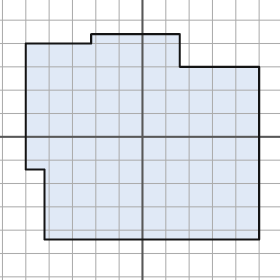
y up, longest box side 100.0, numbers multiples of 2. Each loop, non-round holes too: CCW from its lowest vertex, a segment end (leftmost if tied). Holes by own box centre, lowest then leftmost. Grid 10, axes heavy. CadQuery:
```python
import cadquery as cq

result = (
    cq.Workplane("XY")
    .moveTo(-42.0, -44.0)
    .lineTo(50.0, -44.0)
    .lineTo(50.0, 30.0)
    .lineTo(16.0, 30.0)
    .lineTo(16.0, 44.0)
    .lineTo(-22.0, 44.0)
    .lineTo(-22.0, 40.0)
    .lineTo(-50.0, 40.0)
    .lineTo(-50.0, -14.0)
    .lineTo(-42.0, -14.0)
    .close()
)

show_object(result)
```